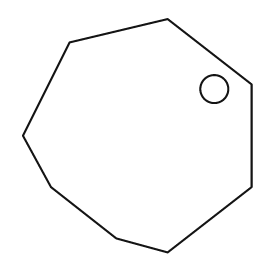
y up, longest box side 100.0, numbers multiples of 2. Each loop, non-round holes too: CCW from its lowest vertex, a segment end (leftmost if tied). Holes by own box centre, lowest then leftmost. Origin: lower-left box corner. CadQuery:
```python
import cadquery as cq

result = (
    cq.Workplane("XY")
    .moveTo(62.0, 0.0)
    .lineTo(98.0, 28.0)
    .lineTo(98.0, 72.0)
    .lineTo(62.0, 100.0)
    .lineTo(20.0, 90.0)
    .lineTo(0.0, 50.0)
    .lineTo(12.0, 28.0)
    .lineTo(40.0, 6.0)
    .close()
    .moveTo(82.0, 70.0)
    .circle(6.0)
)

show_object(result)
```